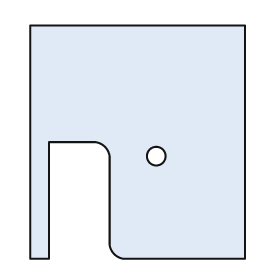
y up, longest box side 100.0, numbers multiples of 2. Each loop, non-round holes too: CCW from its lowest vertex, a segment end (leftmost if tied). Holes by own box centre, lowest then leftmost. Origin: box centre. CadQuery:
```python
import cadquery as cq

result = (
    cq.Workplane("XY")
    .moveTo(-46.0, -50.0)
    .lineTo(-38.0, -50.0)
    .lineTo(-38.0, 0.0)
    .lineTo(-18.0, 0.0)
    .threePointArc((-14.0, -2.0), (-12.0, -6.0))
    .lineTo(-12.0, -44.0)
    .threePointArc((-10.0, -48.0), (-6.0, -50.0))
    .lineTo(46.0, -50.0)
    .lineTo(46.0, 50.0)
    .lineTo(-46.0, 50.0)
    .close()
    .moveTo(8.0, -6.0)
    .circle(4.0)
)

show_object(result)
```